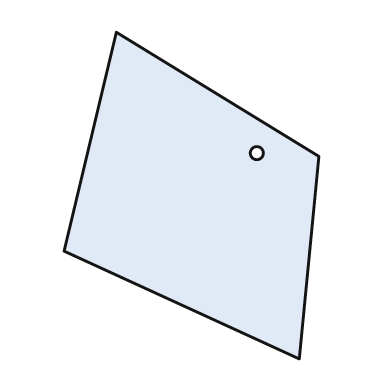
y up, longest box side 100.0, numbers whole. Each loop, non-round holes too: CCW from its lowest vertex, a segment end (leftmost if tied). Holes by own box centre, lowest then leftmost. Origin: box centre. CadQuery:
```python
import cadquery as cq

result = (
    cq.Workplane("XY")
    .moveTo(33.0, -50.0)
    .lineTo(39.0, 12.0)
    .lineTo(-23.0, 50.0)
    .lineTo(-39.0, -17.0)
    .close()
    .moveTo(20.0, 13.0)
    .circle(2.0)
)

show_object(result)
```